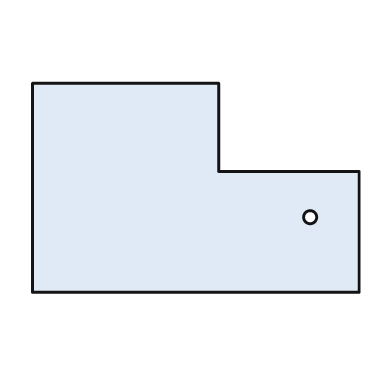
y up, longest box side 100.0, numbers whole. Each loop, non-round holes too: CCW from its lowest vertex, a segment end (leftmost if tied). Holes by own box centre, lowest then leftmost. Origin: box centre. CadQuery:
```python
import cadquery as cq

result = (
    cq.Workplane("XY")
    .moveTo(-50.0, -32.0)
    .lineTo(50.0, -32.0)
    .lineTo(50.0, 5.0)
    .lineTo(7.0, 5.0)
    .lineTo(7.0, 32.0)
    .lineTo(-50.0, 32.0)
    .close()
    .moveTo(35.0, -9.0)
    .circle(2.0)
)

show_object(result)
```